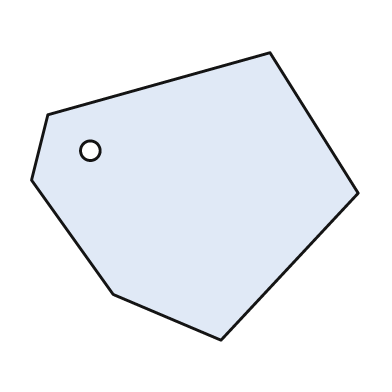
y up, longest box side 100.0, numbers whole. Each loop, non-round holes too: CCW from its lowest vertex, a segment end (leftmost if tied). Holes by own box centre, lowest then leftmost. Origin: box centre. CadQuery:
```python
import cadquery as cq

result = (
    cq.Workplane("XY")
    .moveTo(8.0, -44.0)
    .lineTo(50.0, 1.0)
    .lineTo(23.0, 44.0)
    .lineTo(-45.0, 25.0)
    .lineTo(-50.0, 5.0)
    .lineTo(-25.0, -30.0)
    .close()
    .moveTo(-32.0, 14.0)
    .circle(3.0)
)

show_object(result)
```